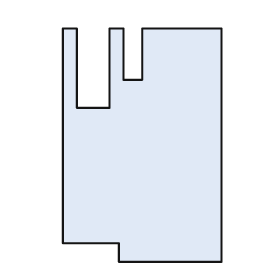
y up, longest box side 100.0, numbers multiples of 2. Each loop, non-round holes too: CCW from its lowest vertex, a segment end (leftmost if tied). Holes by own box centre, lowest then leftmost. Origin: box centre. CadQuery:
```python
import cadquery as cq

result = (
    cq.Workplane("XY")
    .moveTo(-10.0, -50.0)
    .lineTo(34.0, -50.0)
    .lineTo(34.0, 50.0)
    .lineTo(0.0, 50.0)
    .lineTo(0.0, 28.0)
    .lineTo(-8.0, 28.0)
    .lineTo(-8.0, 50.0)
    .lineTo(-14.0, 50.0)
    .lineTo(-14.0, 16.0)
    .lineTo(-28.0, 16.0)
    .lineTo(-28.0, 50.0)
    .lineTo(-34.0, 50.0)
    .lineTo(-34.0, -42.0)
    .lineTo(-10.0, -42.0)
    .close()
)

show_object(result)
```